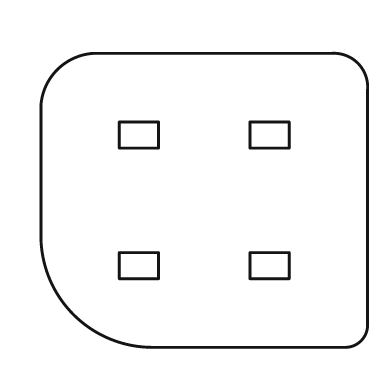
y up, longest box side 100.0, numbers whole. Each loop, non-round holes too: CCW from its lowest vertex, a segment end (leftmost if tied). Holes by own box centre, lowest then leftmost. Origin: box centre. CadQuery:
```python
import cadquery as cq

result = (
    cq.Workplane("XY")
    .moveTo(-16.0, -45.0)
    .lineTo(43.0, -45.0)
    .threePointArc((48.0, -43.0), (50.0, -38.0))
    .lineTo(50.0, 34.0)
    .threePointArc((47.0, 42.0), (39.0, 45.0))
    .lineTo(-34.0, 45.0)
    .threePointArc((-45.0, 40.0), (-50.0, 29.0))
    .lineTo(-50.0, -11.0)
    .threePointArc((-40.0, -35.0), (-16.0, -45.0))
    .close()
    .moveTo(-26.0, -24.0)
    .lineTo(-14.0, -24.0)
    .lineTo(-14.0, -16.0)
    .lineTo(-26.0, -16.0)
    .close()
    .moveTo(14.0, -24.0)
    .lineTo(26.0, -24.0)
    .lineTo(26.0, -16.0)
    .lineTo(14.0, -16.0)
    .close()
    .moveTo(-26.0, 16.0)
    .lineTo(-14.0, 16.0)
    .lineTo(-14.0, 24.0)
    .lineTo(-26.0, 24.0)
    .close()
    .moveTo(14.0, 16.0)
    .lineTo(26.0, 16.0)
    .lineTo(26.0, 24.0)
    .lineTo(14.0, 24.0)
    .close()
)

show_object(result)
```